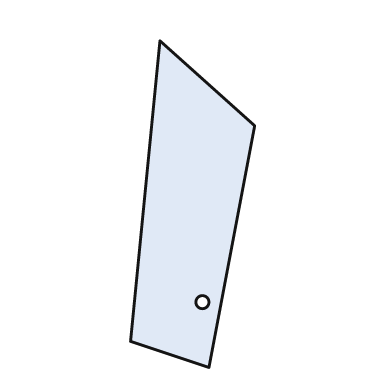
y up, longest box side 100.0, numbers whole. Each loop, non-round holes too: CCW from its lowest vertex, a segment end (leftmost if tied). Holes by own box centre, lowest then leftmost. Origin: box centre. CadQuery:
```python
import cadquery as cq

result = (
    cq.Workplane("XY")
    .moveTo(5.0, -50.0)
    .lineTo(19.0, 24.0)
    .lineTo(-10.0, 50.0)
    .lineTo(-19.0, -42.0)
    .close()
    .moveTo(3.0, -30.0)
    .circle(2.0)
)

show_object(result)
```